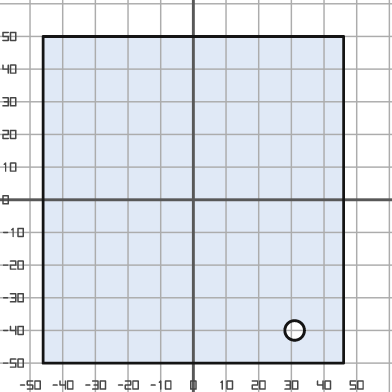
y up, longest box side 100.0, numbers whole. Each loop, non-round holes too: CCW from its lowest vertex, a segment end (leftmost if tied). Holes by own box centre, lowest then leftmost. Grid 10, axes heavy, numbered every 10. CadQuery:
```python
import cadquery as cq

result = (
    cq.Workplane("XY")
    .moveTo(-46.0, -50.0)
    .lineTo(46.0, -50.0)
    .lineTo(46.0, 50.0)
    .lineTo(-46.0, 50.0)
    .close()
    .moveTo(31.0, -40.0)
    .circle(3.0)
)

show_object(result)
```